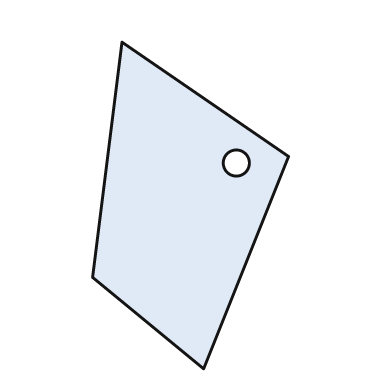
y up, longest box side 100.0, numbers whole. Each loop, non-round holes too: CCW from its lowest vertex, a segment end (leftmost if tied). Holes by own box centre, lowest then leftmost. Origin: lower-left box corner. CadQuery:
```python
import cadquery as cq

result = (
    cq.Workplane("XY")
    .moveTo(34.0, 0.0)
    .lineTo(60.0, 65.0)
    .lineTo(9.0, 100.0)
    .lineTo(0.0, 28.0)
    .close()
    .moveTo(44.0, 63.0)
    .circle(4.0)
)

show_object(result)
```